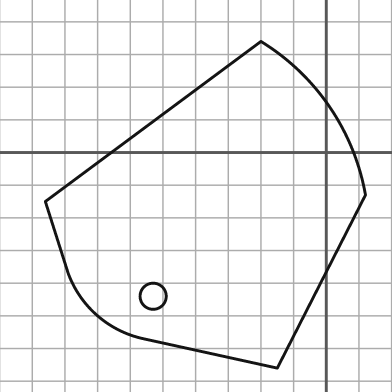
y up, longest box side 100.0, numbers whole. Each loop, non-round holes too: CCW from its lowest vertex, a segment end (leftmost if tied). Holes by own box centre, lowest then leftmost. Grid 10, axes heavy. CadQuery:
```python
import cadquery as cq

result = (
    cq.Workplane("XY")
    .moveTo(-15.0, -66.0)
    .lineTo(12.0, -13.0)
    .threePointArc((1.0, 14.0), (-20.0, 34.0))
    .lineTo(-86.0, -15.0)
    .lineTo(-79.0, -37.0)
    .threePointArc((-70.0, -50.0), (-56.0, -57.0))
    .close()
    .moveTo(-53.0, -44.0)
    .circle(4.0)
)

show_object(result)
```